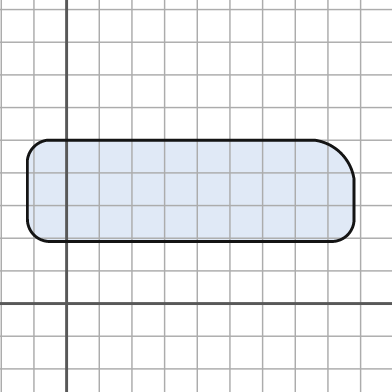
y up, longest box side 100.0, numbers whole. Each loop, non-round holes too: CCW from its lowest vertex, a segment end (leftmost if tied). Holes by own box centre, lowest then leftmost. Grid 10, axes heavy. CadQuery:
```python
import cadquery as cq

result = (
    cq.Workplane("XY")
    .moveTo(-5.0, 19.0)
    .lineTo(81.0, 19.0)
    .threePointArc((86.0, 21.0), (88.0, 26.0))
    .lineTo(88.0, 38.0)
    .threePointArc((84.0, 46.0), (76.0, 50.0))
    .lineTo(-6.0, 50.0)
    .threePointArc((-10.0, 48.0), (-12.0, 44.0))
    .lineTo(-12.0, 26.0)
    .threePointArc((-10.0, 21.0), (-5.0, 19.0))
    .close()
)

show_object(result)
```